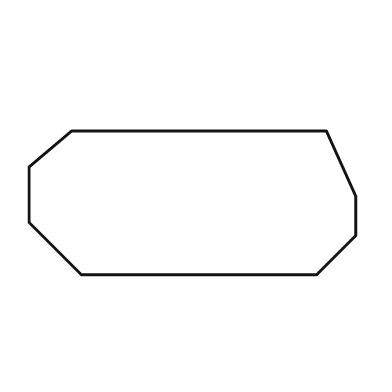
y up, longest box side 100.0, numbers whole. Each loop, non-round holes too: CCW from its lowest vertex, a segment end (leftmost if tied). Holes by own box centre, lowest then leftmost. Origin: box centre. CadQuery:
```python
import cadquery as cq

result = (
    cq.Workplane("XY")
    .moveTo(-34.0, -22.0)
    .lineTo(38.0, -22.0)
    .lineTo(50.0, -10.0)
    .lineTo(50.0, 2.0)
    .lineTo(41.0, 22.0)
    .lineTo(-37.0, 22.0)
    .lineTo(-50.0, 11.0)
    .lineTo(-50.0, -6.0)
    .close()
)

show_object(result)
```